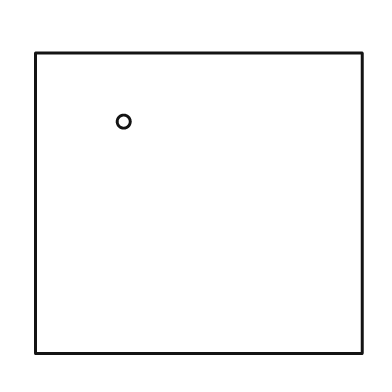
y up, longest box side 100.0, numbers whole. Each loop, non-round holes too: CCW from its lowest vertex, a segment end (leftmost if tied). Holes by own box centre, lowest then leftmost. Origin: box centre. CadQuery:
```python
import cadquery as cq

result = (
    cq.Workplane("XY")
    .moveTo(-50.0, -46.0)
    .lineTo(50.0, -46.0)
    .lineTo(50.0, 46.0)
    .lineTo(-50.0, 46.0)
    .close()
    .moveTo(-23.0, 25.0)
    .circle(2.0)
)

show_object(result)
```